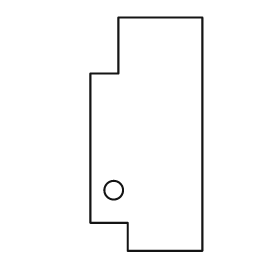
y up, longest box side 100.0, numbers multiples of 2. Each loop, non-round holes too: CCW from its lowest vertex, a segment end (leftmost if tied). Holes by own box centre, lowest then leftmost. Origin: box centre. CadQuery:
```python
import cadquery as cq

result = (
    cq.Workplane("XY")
    .moveTo(-8.0, -50.0)
    .lineTo(24.0, -50.0)
    .lineTo(24.0, 50.0)
    .lineTo(-12.0, 50.0)
    .lineTo(-12.0, 26.0)
    .lineTo(-24.0, 26.0)
    .lineTo(-24.0, -38.0)
    .lineTo(-8.0, -38.0)
    .close()
    .moveTo(-14.0, -24.0)
    .circle(4.0)
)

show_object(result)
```